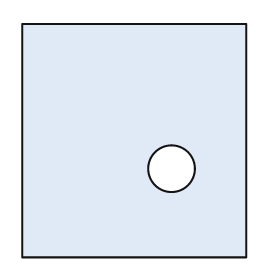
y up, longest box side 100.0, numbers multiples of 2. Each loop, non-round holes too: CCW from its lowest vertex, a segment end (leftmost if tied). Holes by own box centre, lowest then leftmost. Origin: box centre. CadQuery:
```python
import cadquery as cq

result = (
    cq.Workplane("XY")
    .moveTo(-48.0, -50.0)
    .lineTo(48.0, -50.0)
    .lineTo(48.0, 50.0)
    .lineTo(-48.0, 50.0)
    .close()
    .moveTo(16.0, -12.0)
    .circle(10.0)
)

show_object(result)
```